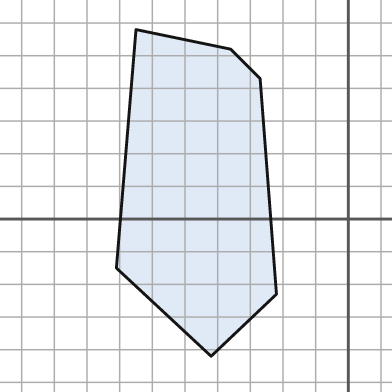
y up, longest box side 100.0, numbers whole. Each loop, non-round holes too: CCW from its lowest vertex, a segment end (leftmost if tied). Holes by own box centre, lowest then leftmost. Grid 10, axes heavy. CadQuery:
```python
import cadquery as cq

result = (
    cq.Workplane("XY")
    .moveTo(-42.0, -42.0)
    .lineTo(-22.0, -23.0)
    .lineTo(-27.0, 43.0)
    .lineTo(-36.0, 52.0)
    .lineTo(-65.0, 58.0)
    .lineTo(-71.0, -15.0)
    .close()
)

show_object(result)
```